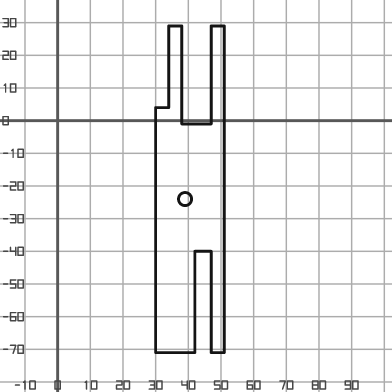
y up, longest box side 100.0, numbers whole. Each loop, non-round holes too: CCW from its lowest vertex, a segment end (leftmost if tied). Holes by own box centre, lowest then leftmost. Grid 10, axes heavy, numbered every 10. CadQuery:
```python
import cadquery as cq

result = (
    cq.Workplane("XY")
    .moveTo(30.0, -71.0)
    .lineTo(42.0, -71.0)
    .lineTo(42.0, -40.0)
    .lineTo(47.0, -40.0)
    .lineTo(47.0, -71.0)
    .lineTo(51.0, -71.0)
    .lineTo(51.0, 29.0)
    .lineTo(47.0, 29.0)
    .lineTo(47.0, -1.0)
    .lineTo(38.0, -1.0)
    .lineTo(38.0, 29.0)
    .lineTo(34.0, 29.0)
    .lineTo(34.0, 4.0)
    .lineTo(30.0, 4.0)
    .close()
    .moveTo(39.0, -24.0)
    .circle(2.0)
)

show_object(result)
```